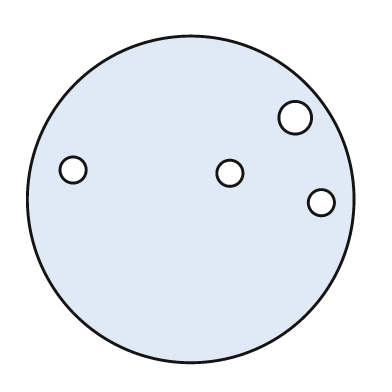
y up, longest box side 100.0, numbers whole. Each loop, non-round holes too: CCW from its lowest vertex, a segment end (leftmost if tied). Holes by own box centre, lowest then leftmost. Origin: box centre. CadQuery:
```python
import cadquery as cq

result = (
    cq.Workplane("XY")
    .moveTo(0.0, 0.0)
    .circle(50.0)
    .moveTo(40.0, -1.0)
    .circle(4.0)
    .moveTo(12.0, 8.0)
    .circle(4.0)
    .moveTo(-36.0, 9.0)
    .circle(4.0)
    .moveTo(32.0, 25.0)
    .circle(5.0)
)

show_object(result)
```